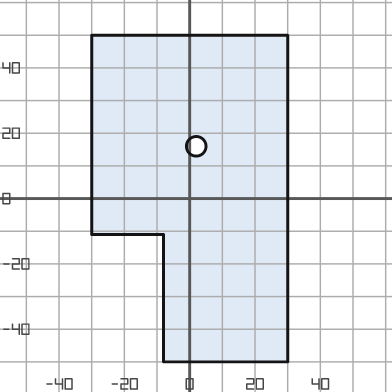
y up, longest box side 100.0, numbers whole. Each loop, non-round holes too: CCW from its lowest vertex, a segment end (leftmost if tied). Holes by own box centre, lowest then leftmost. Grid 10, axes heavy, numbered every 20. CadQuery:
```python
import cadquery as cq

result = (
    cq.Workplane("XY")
    .moveTo(-8.0, -50.0)
    .lineTo(30.0, -50.0)
    .lineTo(30.0, 50.0)
    .lineTo(-30.0, 50.0)
    .lineTo(-30.0, -11.0)
    .lineTo(-8.0, -11.0)
    .close()
    .moveTo(2.0, 16.0)
    .circle(3.0)
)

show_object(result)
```